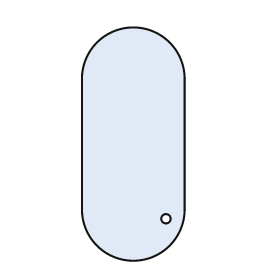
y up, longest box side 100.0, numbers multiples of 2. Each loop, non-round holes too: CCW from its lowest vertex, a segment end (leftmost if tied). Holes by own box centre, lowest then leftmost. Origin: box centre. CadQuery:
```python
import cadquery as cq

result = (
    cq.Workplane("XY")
    .moveTo(-22.0, -28.0)
    .threePointArc((0.0, -50.0), (22.0, -28.0))
    .lineTo(22.0, 28.0)
    .threePointArc((0.0, 50.0), (-22.0, 28.0))
    .close()
    .moveTo(14.0, -32.0)
    .circle(2.0)
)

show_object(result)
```